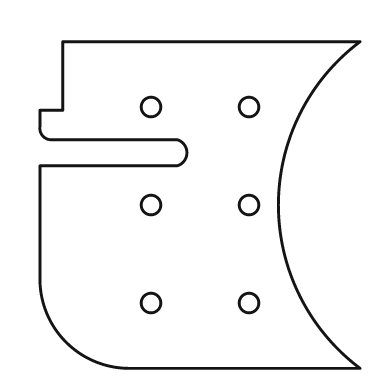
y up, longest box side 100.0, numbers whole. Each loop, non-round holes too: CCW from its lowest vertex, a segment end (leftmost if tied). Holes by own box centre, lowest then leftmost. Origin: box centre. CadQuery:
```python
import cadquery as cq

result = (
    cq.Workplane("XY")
    .moveTo(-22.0, -50.0)
    .lineTo(49.0, -50.0)
    .threePointArc((24.0, 0.0), (49.0, 50.0))
    .lineTo(-42.0, 50.0)
    .lineTo(-42.0, 29.0)
    .lineTo(-49.0, 29.0)
    .lineTo(-49.0, 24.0)
    .threePointArc((-48.0, 21.0), (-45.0, 20.0))
    .lineTo(-7.0, 20.0)
    .threePointArc((-4.0, 16.0), (-7.0, 12.0))
    .lineTo(-49.0, 12.0)
    .lineTo(-49.0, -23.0)
    .threePointArc((-41.0, -42.0), (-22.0, -50.0))
    .close()
    .moveTo(-15.0, -30.0)
    .circle(3.0)
    .moveTo(15.0, -30.0)
    .circle(3.0)
    .moveTo(-15.0, 0.0)
    .circle(3.0)
    .moveTo(15.0, 0.0)
    .circle(3.0)
    .moveTo(-15.0, 30.0)
    .circle(3.0)
    .moveTo(15.0, 30.0)
    .circle(3.0)
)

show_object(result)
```